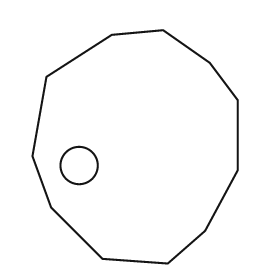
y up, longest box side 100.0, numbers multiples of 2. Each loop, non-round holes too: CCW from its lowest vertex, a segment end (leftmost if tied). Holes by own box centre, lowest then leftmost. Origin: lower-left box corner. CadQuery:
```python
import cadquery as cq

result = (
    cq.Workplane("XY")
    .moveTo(58.0, 0.0)
    .lineTo(74.0, 14.0)
    .lineTo(88.0, 40.0)
    .lineTo(88.0, 70.0)
    .lineTo(76.0, 86.0)
    .lineTo(56.0, 100.0)
    .lineTo(34.0, 98.0)
    .lineTo(6.0, 80.0)
    .lineTo(0.0, 46.0)
    .lineTo(8.0, 24.0)
    .lineTo(30.0, 2.0)
    .close()
    .moveTo(20.0, 42.0)
    .circle(8.0)
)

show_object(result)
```